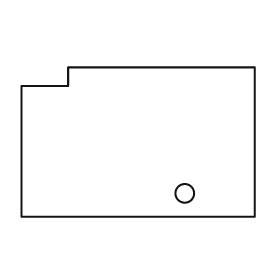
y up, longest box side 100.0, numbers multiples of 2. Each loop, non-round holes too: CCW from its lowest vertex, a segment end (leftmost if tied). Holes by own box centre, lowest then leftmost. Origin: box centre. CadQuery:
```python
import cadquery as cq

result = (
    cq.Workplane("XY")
    .moveTo(-50.0, -32.0)
    .lineTo(50.0, -32.0)
    .lineTo(50.0, 32.0)
    .lineTo(-30.0, 32.0)
    .lineTo(-30.0, 24.0)
    .lineTo(-50.0, 24.0)
    .close()
    .moveTo(20.0, -22.0)
    .circle(4.0)
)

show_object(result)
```